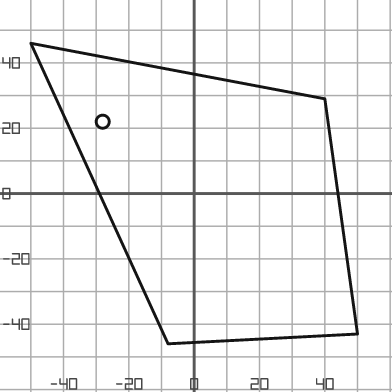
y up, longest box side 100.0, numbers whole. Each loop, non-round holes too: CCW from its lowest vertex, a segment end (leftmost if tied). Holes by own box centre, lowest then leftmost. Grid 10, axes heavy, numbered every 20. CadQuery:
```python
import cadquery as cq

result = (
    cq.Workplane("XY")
    .moveTo(-8.0, -46.0)
    .lineTo(50.0, -43.0)
    .lineTo(40.0, 29.0)
    .lineTo(-50.0, 46.0)
    .close()
    .moveTo(-28.0, 22.0)
    .circle(2.0)
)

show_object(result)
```